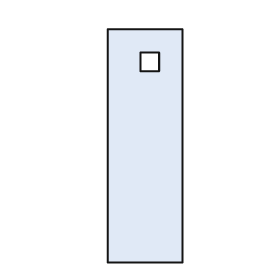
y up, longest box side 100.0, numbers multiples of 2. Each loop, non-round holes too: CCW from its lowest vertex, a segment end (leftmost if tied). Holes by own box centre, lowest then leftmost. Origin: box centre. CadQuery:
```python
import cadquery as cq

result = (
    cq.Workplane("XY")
    .moveTo(-16.0, -50.0)
    .lineTo(16.0, -50.0)
    .lineTo(16.0, 50.0)
    .lineTo(-16.0, 50.0)
    .close()
    .moveTo(-2.0, 32.0)
    .lineTo(6.0, 32.0)
    .lineTo(6.0, 40.0)
    .lineTo(-2.0, 40.0)
    .close()
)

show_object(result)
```